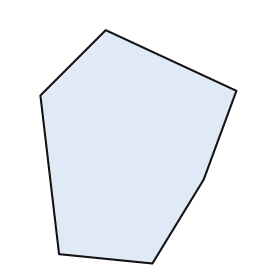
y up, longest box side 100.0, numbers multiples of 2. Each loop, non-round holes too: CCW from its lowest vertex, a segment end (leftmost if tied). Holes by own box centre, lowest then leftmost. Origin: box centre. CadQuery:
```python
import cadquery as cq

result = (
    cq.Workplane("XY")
    .moveTo(6.0, -50.0)
    .lineTo(28.0, -14.0)
    .lineTo(42.0, 24.0)
    .lineTo(-14.0, 50.0)
    .lineTo(-42.0, 22.0)
    .lineTo(-34.0, -46.0)
    .close()
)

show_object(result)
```